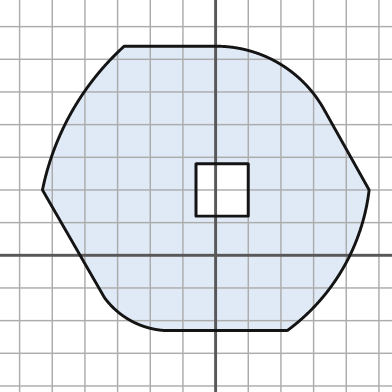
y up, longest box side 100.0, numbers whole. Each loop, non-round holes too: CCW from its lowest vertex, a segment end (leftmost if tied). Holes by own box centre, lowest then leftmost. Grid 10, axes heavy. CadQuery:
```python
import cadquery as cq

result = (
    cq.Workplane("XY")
    .moveTo(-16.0, -23.0)
    .lineTo(22.0, -23.0)
    .threePointArc((39.0, -4.0), (47.0, 20.0))
    .lineTo(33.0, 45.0)
    .threePointArc((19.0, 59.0), (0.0, 64.0))
    .lineTo(-28.0, 64.0)
    .threePointArc((-44.0, 44.0), (-53.0, 20.0))
    .lineTo(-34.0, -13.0)
    .threePointArc((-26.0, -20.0), (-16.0, -23.0))
    .close()
    .moveTo(-6.0, 12.0)
    .lineTo(10.0, 12.0)
    .lineTo(10.0, 28.0)
    .lineTo(-6.0, 28.0)
    .close()
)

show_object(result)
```